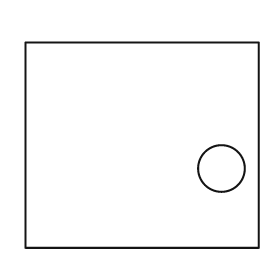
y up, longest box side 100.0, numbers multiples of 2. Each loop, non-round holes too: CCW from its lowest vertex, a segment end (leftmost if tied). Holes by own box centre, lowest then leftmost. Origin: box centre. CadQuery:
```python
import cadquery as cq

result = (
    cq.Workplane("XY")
    .moveTo(-50.0, -44.0)
    .lineTo(50.0, -44.0)
    .lineTo(50.0, 44.0)
    .lineTo(-50.0, 44.0)
    .close()
    .moveTo(34.0, -10.0)
    .circle(10.0)
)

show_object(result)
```